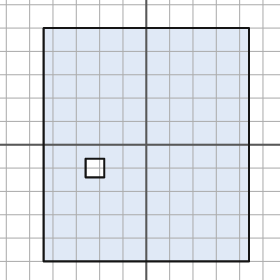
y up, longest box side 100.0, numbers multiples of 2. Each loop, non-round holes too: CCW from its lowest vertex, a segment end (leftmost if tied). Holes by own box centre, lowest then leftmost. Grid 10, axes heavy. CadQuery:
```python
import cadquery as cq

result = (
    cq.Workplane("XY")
    .moveTo(-44.0, -50.0)
    .lineTo(44.0, -50.0)
    .lineTo(44.0, 50.0)
    .lineTo(-44.0, 50.0)
    .close()
    .moveTo(-26.0, -14.0)
    .lineTo(-18.0, -14.0)
    .lineTo(-18.0, -6.0)
    .lineTo(-26.0, -6.0)
    .close()
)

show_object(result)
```